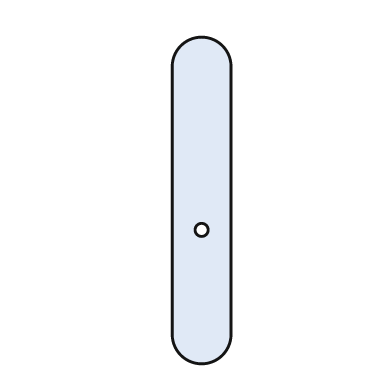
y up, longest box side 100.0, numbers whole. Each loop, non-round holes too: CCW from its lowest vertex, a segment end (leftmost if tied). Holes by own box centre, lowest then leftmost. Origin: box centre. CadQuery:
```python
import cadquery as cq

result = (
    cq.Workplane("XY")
    .moveTo(-9.0, -41.0)
    .threePointArc((0.0, -50.0), (9.0, -41.0))
    .lineTo(9.0, 41.0)
    .threePointArc((0.0, 50.0), (-9.0, 41.0))
    .close()
    .moveTo(0.0, -9.0)
    .circle(2.0)
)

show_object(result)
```